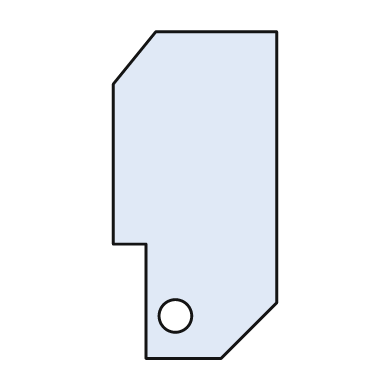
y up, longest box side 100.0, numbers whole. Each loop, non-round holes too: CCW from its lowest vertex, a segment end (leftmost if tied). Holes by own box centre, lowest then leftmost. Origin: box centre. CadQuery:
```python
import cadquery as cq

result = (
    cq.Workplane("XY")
    .moveTo(-15.0, -50.0)
    .lineTo(8.0, -50.0)
    .lineTo(25.0, -33.0)
    .lineTo(25.0, 50.0)
    .lineTo(-12.0, 50.0)
    .lineTo(-25.0, 34.0)
    .lineTo(-25.0, -15.0)
    .lineTo(-15.0, -15.0)
    .close()
    .moveTo(-6.0, -37.0)
    .circle(5.0)
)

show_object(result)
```